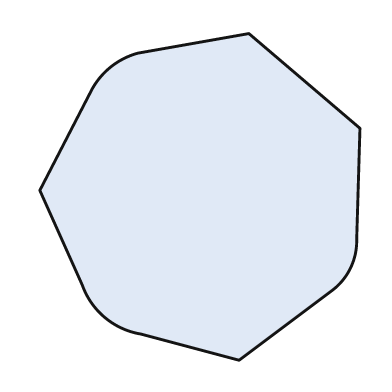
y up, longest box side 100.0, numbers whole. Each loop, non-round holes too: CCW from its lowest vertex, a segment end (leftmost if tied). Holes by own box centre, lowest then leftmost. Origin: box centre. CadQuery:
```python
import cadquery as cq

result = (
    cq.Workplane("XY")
    .moveTo(12.0, -50.0)
    .lineTo(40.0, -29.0)
    .threePointArc((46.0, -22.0), (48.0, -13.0))
    .lineTo(49.0, 21.0)
    .lineTo(15.0, 50.0)
    .lineTo(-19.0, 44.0)
    .threePointArc((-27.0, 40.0), (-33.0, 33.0))
    .lineTo(-49.0, 2.0)
    .lineTo(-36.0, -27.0)
    .threePointArc((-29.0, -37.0), (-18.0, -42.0))
    .close()
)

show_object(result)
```